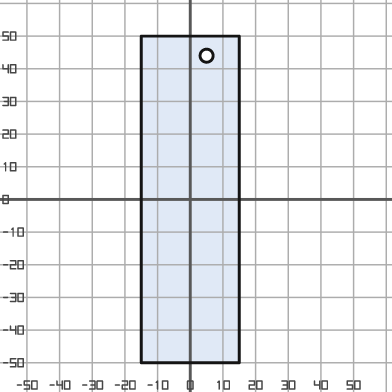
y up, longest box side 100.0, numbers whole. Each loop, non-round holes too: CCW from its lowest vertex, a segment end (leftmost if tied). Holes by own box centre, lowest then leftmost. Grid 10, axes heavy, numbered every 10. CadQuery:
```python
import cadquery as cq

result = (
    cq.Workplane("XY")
    .moveTo(-15.0, -50.0)
    .lineTo(15.0, -50.0)
    .lineTo(15.0, 50.0)
    .lineTo(-15.0, 50.0)
    .close()
    .moveTo(5.0, 44.0)
    .circle(2.0)
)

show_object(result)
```